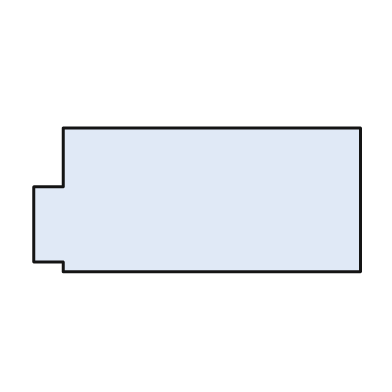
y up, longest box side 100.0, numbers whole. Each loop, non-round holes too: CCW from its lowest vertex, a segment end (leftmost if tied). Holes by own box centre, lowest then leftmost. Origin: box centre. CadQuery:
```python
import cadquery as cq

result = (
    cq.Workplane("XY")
    .moveTo(-41.0, -22.0)
    .lineTo(50.0, -22.0)
    .lineTo(50.0, 22.0)
    .lineTo(-41.0, 22.0)
    .lineTo(-41.0, 4.0)
    .lineTo(-50.0, 4.0)
    .lineTo(-50.0, -19.0)
    .lineTo(-41.0, -19.0)
    .close()
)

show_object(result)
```